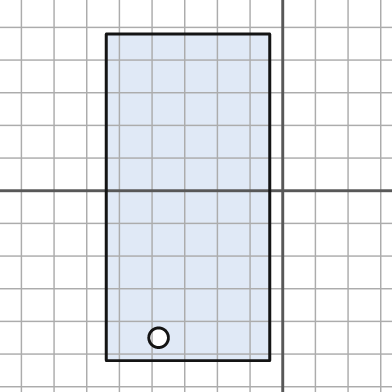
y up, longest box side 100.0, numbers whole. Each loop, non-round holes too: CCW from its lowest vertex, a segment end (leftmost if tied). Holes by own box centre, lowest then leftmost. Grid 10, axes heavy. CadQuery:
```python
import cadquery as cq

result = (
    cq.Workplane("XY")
    .moveTo(-54.0, -52.0)
    .lineTo(-4.0, -52.0)
    .lineTo(-4.0, 48.0)
    .lineTo(-54.0, 48.0)
    .close()
    .moveTo(-38.0, -45.0)
    .circle(3.0)
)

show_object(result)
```